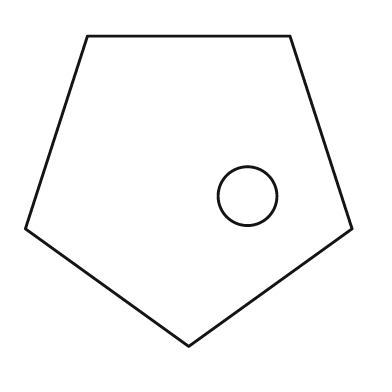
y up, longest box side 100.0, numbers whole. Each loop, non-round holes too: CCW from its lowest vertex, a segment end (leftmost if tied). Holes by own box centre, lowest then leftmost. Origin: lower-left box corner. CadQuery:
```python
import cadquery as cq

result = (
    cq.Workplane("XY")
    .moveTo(50.0, 0.0)
    .lineTo(100.0, 36.0)
    .lineTo(81.0, 95.0)
    .lineTo(19.0, 95.0)
    .lineTo(0.0, 36.0)
    .close()
    .moveTo(68.0, 46.0)
    .circle(9.0)
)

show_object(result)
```